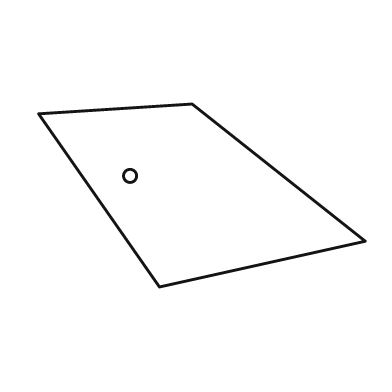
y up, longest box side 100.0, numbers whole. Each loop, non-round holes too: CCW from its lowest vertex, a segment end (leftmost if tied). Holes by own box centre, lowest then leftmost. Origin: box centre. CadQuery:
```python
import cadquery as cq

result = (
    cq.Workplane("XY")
    .moveTo(-13.0, -28.0)
    .lineTo(50.0, -14.0)
    .lineTo(-3.0, 28.0)
    .lineTo(-50.0, 25.0)
    .close()
    .moveTo(-22.0, 6.0)
    .circle(2.0)
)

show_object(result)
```